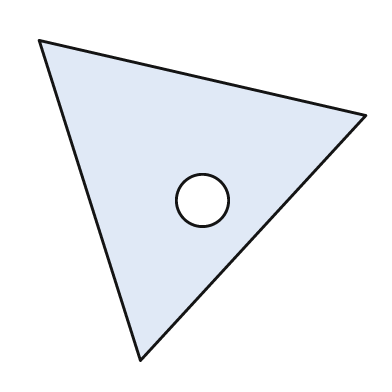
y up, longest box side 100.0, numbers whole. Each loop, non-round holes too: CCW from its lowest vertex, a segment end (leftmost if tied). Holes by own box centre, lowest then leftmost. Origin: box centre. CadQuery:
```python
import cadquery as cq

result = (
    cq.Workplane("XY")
    .moveTo(-19.0, -49.0)
    .lineTo(50.0, 26.0)
    .lineTo(-50.0, 49.0)
    .close()
    .moveTo(0.0, 0.0)
    .circle(8.0)
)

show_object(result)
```